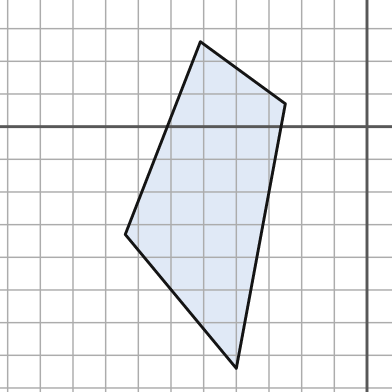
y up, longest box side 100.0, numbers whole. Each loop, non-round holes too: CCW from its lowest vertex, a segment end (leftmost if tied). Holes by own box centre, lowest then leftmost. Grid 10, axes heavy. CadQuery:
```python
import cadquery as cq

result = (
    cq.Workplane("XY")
    .moveTo(-40.0, -74.0)
    .lineTo(-25.0, 7.0)
    .lineTo(-51.0, 26.0)
    .lineTo(-74.0, -33.0)
    .close()
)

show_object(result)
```